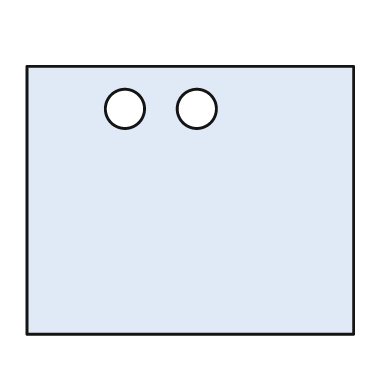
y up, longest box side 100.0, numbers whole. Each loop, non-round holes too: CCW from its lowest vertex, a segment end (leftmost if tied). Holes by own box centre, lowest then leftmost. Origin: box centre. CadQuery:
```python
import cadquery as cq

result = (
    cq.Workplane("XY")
    .moveTo(-50.0, -41.0)
    .lineTo(50.0, -41.0)
    .lineTo(50.0, 41.0)
    .lineTo(-50.0, 41.0)
    .close()
    .moveTo(-20.0, 28.0)
    .circle(6.0)
    .moveTo(2.0, 28.0)
    .circle(6.0)
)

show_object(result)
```